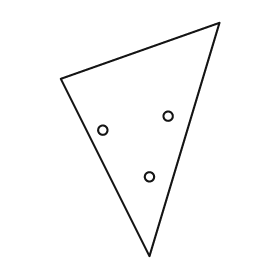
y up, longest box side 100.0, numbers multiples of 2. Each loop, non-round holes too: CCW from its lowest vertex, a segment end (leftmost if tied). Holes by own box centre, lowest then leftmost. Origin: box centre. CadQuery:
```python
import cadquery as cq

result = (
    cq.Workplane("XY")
    .moveTo(4.0, -50.0)
    .lineTo(34.0, 50.0)
    .lineTo(-34.0, 26.0)
    .close()
    .moveTo(4.0, -16.0)
    .circle(2.0)
    .moveTo(-16.0, 4.0)
    .circle(2.0)
    .moveTo(12.0, 10.0)
    .circle(2.0)
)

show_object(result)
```